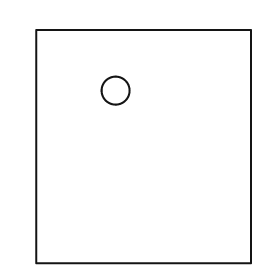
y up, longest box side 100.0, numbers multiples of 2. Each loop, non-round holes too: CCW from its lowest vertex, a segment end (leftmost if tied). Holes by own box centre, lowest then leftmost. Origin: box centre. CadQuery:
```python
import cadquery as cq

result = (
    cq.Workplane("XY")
    .moveTo(-46.0, -50.0)
    .lineTo(46.0, -50.0)
    .lineTo(46.0, 50.0)
    .lineTo(-46.0, 50.0)
    .close()
    .moveTo(-12.0, 24.0)
    .circle(6.0)
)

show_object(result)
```